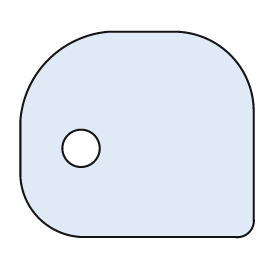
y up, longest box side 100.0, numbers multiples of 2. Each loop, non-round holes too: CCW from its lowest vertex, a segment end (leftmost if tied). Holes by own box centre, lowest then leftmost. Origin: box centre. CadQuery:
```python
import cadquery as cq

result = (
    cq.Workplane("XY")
    .moveTo(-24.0, -44.0)
    .lineTo(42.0, -44.0)
    .threePointArc((48.0, -42.0), (50.0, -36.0))
    .lineTo(50.0, 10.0)
    .threePointArc((40.0, 34.0), (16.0, 44.0))
    .lineTo(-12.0, 44.0)
    .threePointArc((-38.0, 32.0), (-50.0, 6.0))
    .lineTo(-50.0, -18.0)
    .threePointArc((-42.0, -36.0), (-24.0, -44.0))
    .close()
    .moveTo(-24.0, -6.0)
    .circle(8.0)
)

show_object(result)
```